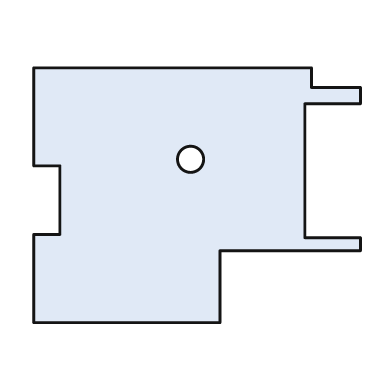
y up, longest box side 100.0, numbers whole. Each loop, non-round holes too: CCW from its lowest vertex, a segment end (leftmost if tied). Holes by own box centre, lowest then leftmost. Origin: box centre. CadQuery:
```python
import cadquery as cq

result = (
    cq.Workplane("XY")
    .moveTo(-50.0, -39.0)
    .lineTo(7.0, -39.0)
    .lineTo(7.0, -17.0)
    .lineTo(50.0, -17.0)
    .lineTo(50.0, -13.0)
    .lineTo(33.0, -13.0)
    .lineTo(33.0, 28.0)
    .lineTo(50.0, 28.0)
    .lineTo(50.0, 33.0)
    .lineTo(35.0, 33.0)
    .lineTo(35.0, 39.0)
    .lineTo(-50.0, 39.0)
    .lineTo(-50.0, 9.0)
    .lineTo(-42.0, 9.0)
    .lineTo(-42.0, -12.0)
    .lineTo(-50.0, -12.0)
    .close()
    .moveTo(-2.0, 11.0)
    .circle(4.0)
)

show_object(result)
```